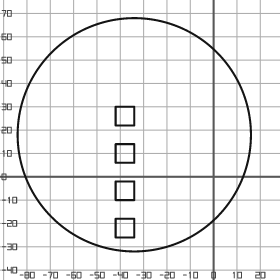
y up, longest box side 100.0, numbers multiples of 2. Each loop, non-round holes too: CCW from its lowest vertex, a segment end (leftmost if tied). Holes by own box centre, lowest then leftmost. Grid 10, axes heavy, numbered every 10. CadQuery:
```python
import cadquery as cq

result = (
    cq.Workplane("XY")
    .moveTo(-34.0, 18.0)
    .circle(50.0)
    .moveTo(-42.0, -26.0)
    .lineTo(-34.0, -26.0)
    .lineTo(-34.0, -18.0)
    .lineTo(-42.0, -18.0)
    .close()
    .moveTo(-42.0, -10.0)
    .lineTo(-34.0, -10.0)
    .lineTo(-34.0, -2.0)
    .lineTo(-42.0, -2.0)
    .close()
    .moveTo(-42.0, 6.0)
    .lineTo(-34.0, 6.0)
    .lineTo(-34.0, 14.0)
    .lineTo(-42.0, 14.0)
    .close()
    .moveTo(-42.0, 22.0)
    .lineTo(-34.0, 22.0)
    .lineTo(-34.0, 30.0)
    .lineTo(-42.0, 30.0)
    .close()
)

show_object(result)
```